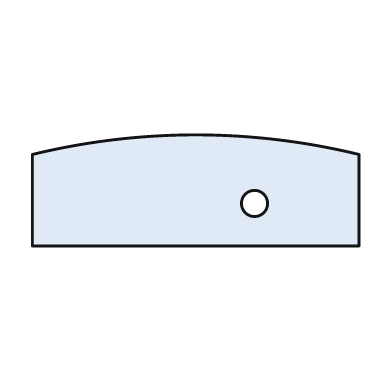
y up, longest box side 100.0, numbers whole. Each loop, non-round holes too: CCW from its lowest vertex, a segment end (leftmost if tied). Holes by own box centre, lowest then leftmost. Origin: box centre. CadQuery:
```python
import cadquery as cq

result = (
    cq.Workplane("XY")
    .moveTo(-50.0, -17.0)
    .lineTo(50.0, -17.0)
    .lineTo(50.0, 11.0)
    .threePointArc((0.0, 17.0), (-50.0, 11.0))
    .close()
    .moveTo(18.0, -4.0)
    .circle(4.0)
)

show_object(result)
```